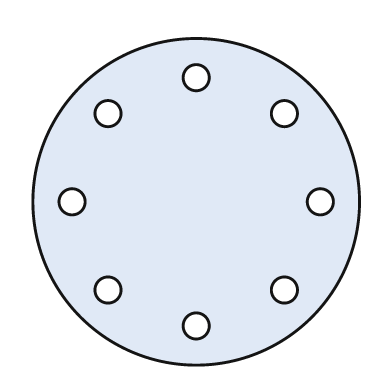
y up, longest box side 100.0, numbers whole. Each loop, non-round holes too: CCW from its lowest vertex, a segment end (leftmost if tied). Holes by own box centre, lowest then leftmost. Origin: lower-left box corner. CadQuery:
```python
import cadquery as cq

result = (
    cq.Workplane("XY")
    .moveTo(50.0, 50.0)
    .circle(50.0)
    .moveTo(50.0, 12.0)
    .circle(4.0)
    .moveTo(23.0, 23.0)
    .circle(4.0)
    .moveTo(77.0, 23.0)
    .circle(4.0)
    .moveTo(12.0, 50.0)
    .circle(4.0)
    .moveTo(88.0, 50.0)
    .circle(4.0)
    .moveTo(23.0, 77.0)
    .circle(4.0)
    .moveTo(77.0, 77.0)
    .circle(4.0)
    .moveTo(50.0, 88.0)
    .circle(4.0)
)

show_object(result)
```